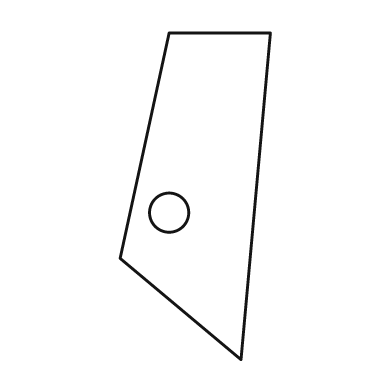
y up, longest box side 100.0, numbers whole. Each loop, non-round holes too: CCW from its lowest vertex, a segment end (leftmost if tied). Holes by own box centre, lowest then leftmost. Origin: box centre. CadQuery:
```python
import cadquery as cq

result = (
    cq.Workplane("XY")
    .moveTo(14.0, -50.0)
    .lineTo(23.0, 50.0)
    .lineTo(-8.0, 50.0)
    .lineTo(-23.0, -19.0)
    .close()
    .moveTo(-8.0, -5.0)
    .circle(6.0)
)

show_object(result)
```